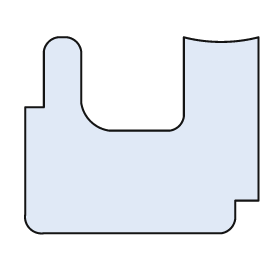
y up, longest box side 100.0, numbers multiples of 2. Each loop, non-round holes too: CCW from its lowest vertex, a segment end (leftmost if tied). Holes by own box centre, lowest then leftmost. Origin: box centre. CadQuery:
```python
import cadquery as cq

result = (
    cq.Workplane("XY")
    .moveTo(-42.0, -42.0)
    .lineTo(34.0, -42.0)
    .threePointArc((38.0, -40.0), (40.0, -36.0))
    .lineTo(40.0, -28.0)
    .lineTo(50.0, -28.0)
    .lineTo(50.0, 42.0)
    .threePointArc((34.0, 40.0), (18.0, 42.0))
    .lineTo(18.0, 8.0)
    .threePointArc((16.0, 4.0), (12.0, 2.0))
    .lineTo(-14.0, 2.0)
    .threePointArc((-22.0, 6.0), (-26.0, 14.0))
    .lineTo(-26.0, 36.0)
    .threePointArc((-28.0, 40.0), (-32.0, 42.0))
    .lineTo(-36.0, 42.0)
    .threePointArc((-40.0, 40.0), (-42.0, 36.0))
    .lineTo(-42.0, 12.0)
    .lineTo(-50.0, 12.0)
    .lineTo(-50.0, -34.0)
    .threePointArc((-48.0, -40.0), (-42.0, -42.0))
    .close()
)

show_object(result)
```